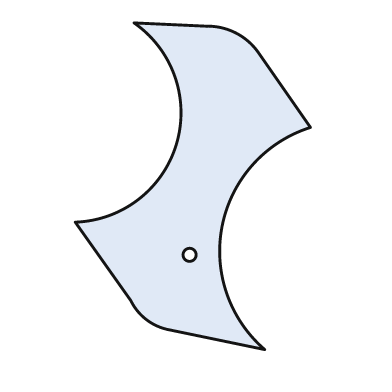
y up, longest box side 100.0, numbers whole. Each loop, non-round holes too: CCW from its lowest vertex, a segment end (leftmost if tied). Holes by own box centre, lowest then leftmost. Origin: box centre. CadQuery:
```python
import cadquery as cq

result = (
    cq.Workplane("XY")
    .moveTo(22.0, -50.0)
    .threePointArc((9.0, -12.0), (36.0, 18.0))
    .lineTo(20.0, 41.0)
    .threePointArc((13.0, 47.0), (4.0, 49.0))
    .lineTo(-18.0, 50.0)
    .threePointArc((-5.0, 13.0), (-36.0, -11.0))
    .lineTo(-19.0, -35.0)
    .threePointArc((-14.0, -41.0), (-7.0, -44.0))
    .close()
    .moveTo(-1.0, -21.0)
    .circle(2.0)
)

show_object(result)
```